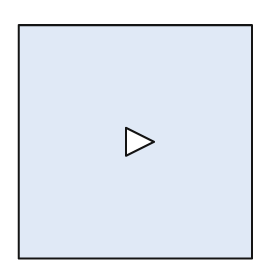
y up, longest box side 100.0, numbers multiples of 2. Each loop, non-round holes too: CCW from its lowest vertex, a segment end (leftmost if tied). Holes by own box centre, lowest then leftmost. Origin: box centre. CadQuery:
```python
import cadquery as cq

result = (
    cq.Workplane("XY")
    .moveTo(-50.0, -50.0)
    .lineTo(50.0, -50.0)
    .lineTo(50.0, 50.0)
    .lineTo(-50.0, 50.0)
    .close()
    .moveTo(-4.0, -6.0)
    .lineTo(8.0, 0.0)
    .lineTo(-4.0, 6.0)
    .close()
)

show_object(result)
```